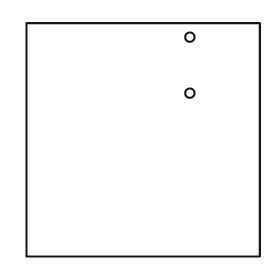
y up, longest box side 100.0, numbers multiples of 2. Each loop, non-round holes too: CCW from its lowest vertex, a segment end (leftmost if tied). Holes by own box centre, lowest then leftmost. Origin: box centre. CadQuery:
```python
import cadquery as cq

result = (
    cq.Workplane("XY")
    .moveTo(-50.0, -50.0)
    .lineTo(50.0, -50.0)
    .lineTo(50.0, 50.0)
    .lineTo(-50.0, 50.0)
    .close()
    .moveTo(20.0, 20.0)
    .circle(2.0)
    .moveTo(20.0, 44.0)
    .circle(2.0)
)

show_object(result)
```